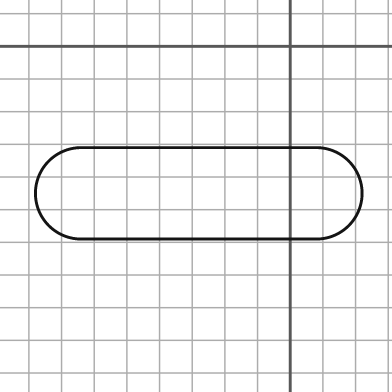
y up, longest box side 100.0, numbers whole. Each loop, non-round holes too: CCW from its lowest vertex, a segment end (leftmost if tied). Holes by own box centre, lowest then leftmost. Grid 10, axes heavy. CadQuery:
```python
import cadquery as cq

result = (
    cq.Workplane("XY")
    .moveTo(-64.0, -59.0)
    .lineTo(8.0, -59.0)
    .threePointArc((22.0, -45.0), (8.0, -31.0))
    .lineTo(-64.0, -31.0)
    .threePointArc((-78.0, -45.0), (-64.0, -59.0))
    .close()
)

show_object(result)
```